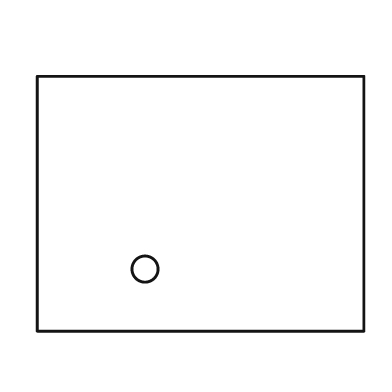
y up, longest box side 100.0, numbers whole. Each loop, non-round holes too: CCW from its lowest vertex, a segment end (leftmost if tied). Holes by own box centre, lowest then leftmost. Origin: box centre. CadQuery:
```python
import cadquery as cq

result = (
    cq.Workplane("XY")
    .moveTo(-50.0, -39.0)
    .lineTo(50.0, -39.0)
    .lineTo(50.0, 39.0)
    .lineTo(-50.0, 39.0)
    .close()
    .moveTo(-17.0, -20.0)
    .circle(4.0)
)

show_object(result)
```